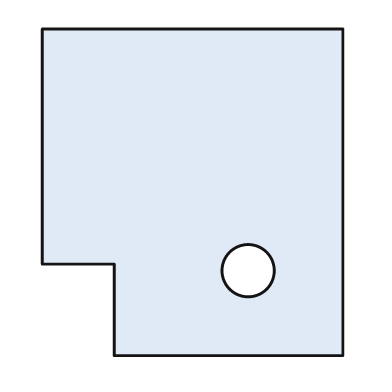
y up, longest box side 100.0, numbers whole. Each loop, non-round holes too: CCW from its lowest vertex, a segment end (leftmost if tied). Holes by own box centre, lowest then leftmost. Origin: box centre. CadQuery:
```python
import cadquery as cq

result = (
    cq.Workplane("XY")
    .moveTo(-24.0, -50.0)
    .lineTo(46.0, -50.0)
    .lineTo(46.0, 50.0)
    .lineTo(-46.0, 50.0)
    .lineTo(-46.0, -22.0)
    .lineTo(-24.0, -22.0)
    .close()
    .moveTo(17.0, -24.0)
    .circle(8.0)
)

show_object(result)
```